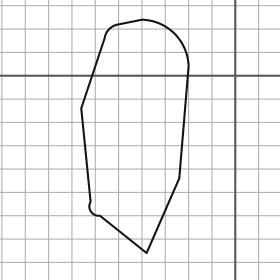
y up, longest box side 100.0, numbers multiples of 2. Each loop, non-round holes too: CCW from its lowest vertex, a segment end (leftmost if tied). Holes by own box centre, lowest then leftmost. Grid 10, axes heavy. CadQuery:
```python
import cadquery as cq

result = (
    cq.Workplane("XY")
    .moveTo(-38.0, -76.0)
    .lineTo(-24.0, -44.0)
    .lineTo(-20.0, 4.0)
    .threePointArc((-26.0, 18.0), (-40.0, 24.0))
    .lineTo(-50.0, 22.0)
    .threePointArc((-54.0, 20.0), (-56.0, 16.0))
    .lineTo(-66.0, -14.0)
    .lineTo(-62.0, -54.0)
    .threePointArc((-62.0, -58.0), (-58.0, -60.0))
    .close()
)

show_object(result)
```